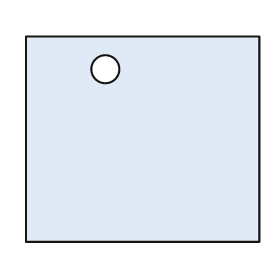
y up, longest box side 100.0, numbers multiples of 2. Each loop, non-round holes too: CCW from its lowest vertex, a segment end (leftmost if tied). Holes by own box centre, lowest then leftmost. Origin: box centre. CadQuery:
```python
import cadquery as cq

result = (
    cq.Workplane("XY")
    .moveTo(-50.0, -44.0)
    .lineTo(50.0, -44.0)
    .lineTo(50.0, 44.0)
    .lineTo(-50.0, 44.0)
    .close()
    .moveTo(-16.0, 30.0)
    .circle(6.0)
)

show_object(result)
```